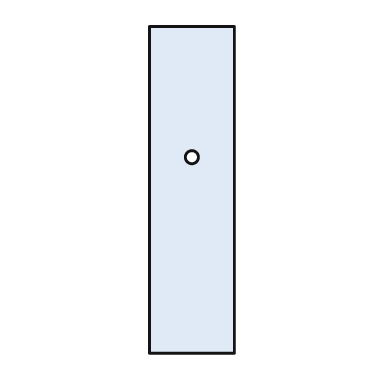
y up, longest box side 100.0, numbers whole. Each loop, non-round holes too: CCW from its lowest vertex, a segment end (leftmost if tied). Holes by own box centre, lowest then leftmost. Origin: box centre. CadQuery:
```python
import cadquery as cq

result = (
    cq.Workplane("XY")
    .moveTo(-13.0, -50.0)
    .lineTo(13.0, -50.0)
    .lineTo(13.0, 50.0)
    .lineTo(-13.0, 50.0)
    .close()
    .moveTo(0.0, 10.0)
    .circle(2.0)
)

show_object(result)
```